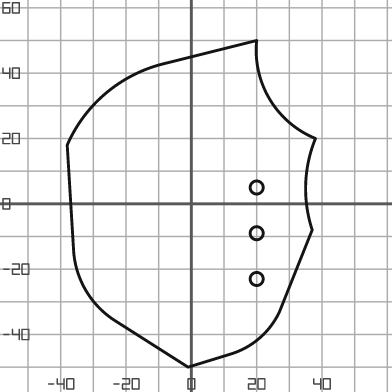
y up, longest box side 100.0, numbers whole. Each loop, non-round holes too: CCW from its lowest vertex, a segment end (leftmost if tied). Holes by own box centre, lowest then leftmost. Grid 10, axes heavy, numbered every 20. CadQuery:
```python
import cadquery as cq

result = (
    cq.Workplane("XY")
    .moveTo(-1.0, -50.0)
    .lineTo(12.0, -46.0)
    .threePointArc((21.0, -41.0), (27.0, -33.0))
    .lineTo(37.0, -8.0)
    .threePointArc((35.0, 6.0), (38.0, 20.0))
    .threePointArc((24.0, 32.0), (20.0, 50.0))
    .lineTo(-8.0, 43.0)
    .threePointArc((-26.0, 34.0), (-38.0, 18.0))
    .lineTo(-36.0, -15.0)
    .threePointArc((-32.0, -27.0), (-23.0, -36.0))
    .close()
    .moveTo(20.0, -23.0)
    .circle(2.0)
    .moveTo(20.0, -9.0)
    .circle(2.0)
    .moveTo(20.0, 5.0)
    .circle(2.0)
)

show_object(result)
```